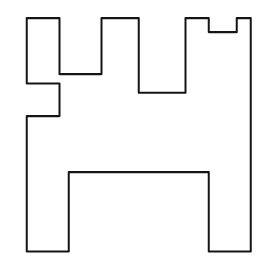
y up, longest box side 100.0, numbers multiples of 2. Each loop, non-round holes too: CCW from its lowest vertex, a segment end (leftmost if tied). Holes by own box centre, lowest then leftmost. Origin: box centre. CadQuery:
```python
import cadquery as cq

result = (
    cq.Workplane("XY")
    .moveTo(-48.0, -50.0)
    .lineTo(-30.0, -50.0)
    .lineTo(-30.0, -16.0)
    .lineTo(30.0, -16.0)
    .lineTo(30.0, -50.0)
    .lineTo(48.0, -50.0)
    .lineTo(48.0, 50.0)
    .lineTo(42.0, 50.0)
    .lineTo(42.0, 44.0)
    .lineTo(30.0, 44.0)
    .lineTo(30.0, 50.0)
    .lineTo(20.0, 50.0)
    .lineTo(20.0, 18.0)
    .lineTo(0.0, 18.0)
    .lineTo(0.0, 50.0)
    .lineTo(-16.0, 50.0)
    .lineTo(-16.0, 26.0)
    .lineTo(-34.0, 26.0)
    .lineTo(-34.0, 50.0)
    .lineTo(-48.0, 50.0)
    .lineTo(-48.0, 22.0)
    .lineTo(-34.0, 22.0)
    .lineTo(-34.0, 8.0)
    .lineTo(-48.0, 8.0)
    .close()
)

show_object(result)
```